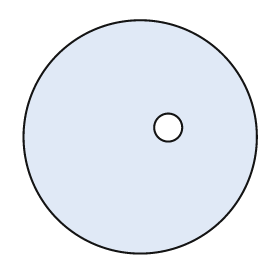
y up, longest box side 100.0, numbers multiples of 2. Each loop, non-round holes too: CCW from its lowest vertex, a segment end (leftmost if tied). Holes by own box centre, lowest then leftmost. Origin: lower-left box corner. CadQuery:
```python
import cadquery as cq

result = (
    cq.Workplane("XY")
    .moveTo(50.0, 50.0)
    .circle(50.0)
    .moveTo(62.0, 54.0)
    .circle(6.0)
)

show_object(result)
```